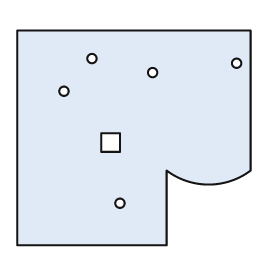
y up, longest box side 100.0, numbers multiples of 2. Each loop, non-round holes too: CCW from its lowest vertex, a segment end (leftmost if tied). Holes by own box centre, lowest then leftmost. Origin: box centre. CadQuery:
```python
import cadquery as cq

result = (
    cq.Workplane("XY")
    .moveTo(-50.0, -46.0)
    .lineTo(14.0, -46.0)
    .lineTo(14.0, -14.0)
    .threePointArc((32.0, -20.0), (50.0, -14.0))
    .lineTo(50.0, 46.0)
    .lineTo(-50.0, 46.0)
    .close()
    .moveTo(-6.0, -28.0)
    .circle(2.0)
    .moveTo(-14.0, -6.0)
    .lineTo(-6.0, -6.0)
    .lineTo(-6.0, 2.0)
    .lineTo(-14.0, 2.0)
    .close()
    .moveTo(-30.0, 20.0)
    .circle(2.0)
    .moveTo(8.0, 28.0)
    .circle(2.0)
    .moveTo(44.0, 32.0)
    .circle(2.0)
    .moveTo(-18.0, 34.0)
    .circle(2.0)
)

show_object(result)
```